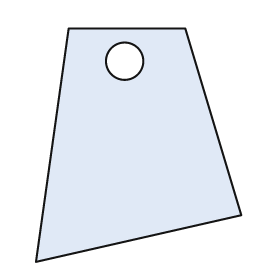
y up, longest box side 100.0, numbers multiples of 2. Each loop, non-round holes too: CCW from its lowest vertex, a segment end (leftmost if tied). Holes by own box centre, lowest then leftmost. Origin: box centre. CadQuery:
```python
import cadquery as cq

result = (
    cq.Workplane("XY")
    .moveTo(-44.0, -50.0)
    .lineTo(44.0, -30.0)
    .lineTo(20.0, 50.0)
    .lineTo(-30.0, 50.0)
    .close()
    .moveTo(-6.0, 36.0)
    .circle(8.0)
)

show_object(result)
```